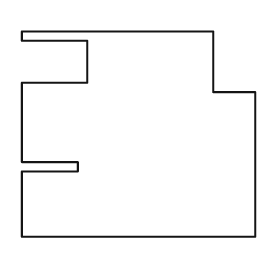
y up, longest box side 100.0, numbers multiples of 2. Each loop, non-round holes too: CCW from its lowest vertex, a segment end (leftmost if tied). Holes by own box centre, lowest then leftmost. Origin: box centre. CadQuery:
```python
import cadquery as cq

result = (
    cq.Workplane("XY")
    .moveTo(-50.0, -44.0)
    .lineTo(50.0, -44.0)
    .lineTo(50.0, 18.0)
    .lineTo(32.0, 18.0)
    .lineTo(32.0, 44.0)
    .lineTo(-50.0, 44.0)
    .lineTo(-50.0, 40.0)
    .lineTo(-22.0, 40.0)
    .lineTo(-22.0, 22.0)
    .lineTo(-50.0, 22.0)
    .lineTo(-50.0, -12.0)
    .lineTo(-26.0, -12.0)
    .lineTo(-26.0, -16.0)
    .lineTo(-50.0, -16.0)
    .close()
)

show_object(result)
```